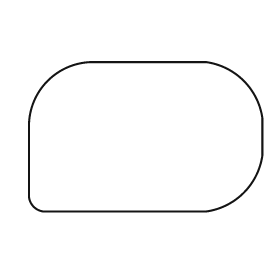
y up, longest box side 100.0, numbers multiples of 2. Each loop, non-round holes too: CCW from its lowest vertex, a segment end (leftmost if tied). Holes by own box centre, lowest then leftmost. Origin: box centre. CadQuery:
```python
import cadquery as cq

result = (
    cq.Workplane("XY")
    .moveTo(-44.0, -32.0)
    .lineTo(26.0, -32.0)
    .threePointArc((42.0, -24.0), (50.0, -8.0))
    .lineTo(50.0, 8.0)
    .threePointArc((42.0, 24.0), (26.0, 32.0))
    .lineTo(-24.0, 32.0)
    .threePointArc((-42.0, 24.0), (-50.0, 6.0))
    .lineTo(-50.0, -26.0)
    .threePointArc((-48.0, -30.0), (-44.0, -32.0))
    .close()
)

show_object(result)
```